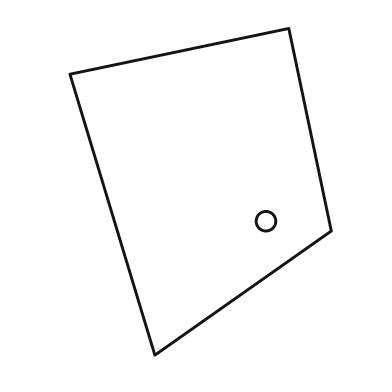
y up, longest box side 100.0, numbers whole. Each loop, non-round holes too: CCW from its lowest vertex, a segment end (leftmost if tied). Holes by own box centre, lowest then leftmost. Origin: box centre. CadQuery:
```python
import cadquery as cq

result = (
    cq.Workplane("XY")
    .moveTo(-14.0, -50.0)
    .lineTo(40.0, -12.0)
    .lineTo(27.0, 50.0)
    .lineTo(-40.0, 36.0)
    .close()
    .moveTo(20.0, -9.0)
    .circle(3.0)
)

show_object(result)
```